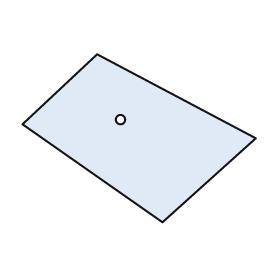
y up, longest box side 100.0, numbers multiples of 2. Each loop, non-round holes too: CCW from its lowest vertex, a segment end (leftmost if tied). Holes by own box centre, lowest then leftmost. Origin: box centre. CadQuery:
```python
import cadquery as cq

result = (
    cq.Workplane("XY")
    .moveTo(10.0, -36.0)
    .lineTo(50.0, 0.0)
    .lineTo(-18.0, 36.0)
    .lineTo(-50.0, 6.0)
    .close()
    .moveTo(-8.0, 8.0)
    .circle(2.0)
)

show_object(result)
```